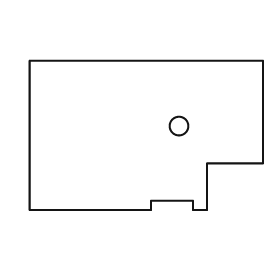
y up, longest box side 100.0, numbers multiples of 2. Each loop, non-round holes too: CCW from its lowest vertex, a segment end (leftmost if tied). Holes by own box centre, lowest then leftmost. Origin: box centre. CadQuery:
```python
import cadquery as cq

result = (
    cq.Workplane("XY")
    .moveTo(-50.0, -32.0)
    .lineTo(2.0, -32.0)
    .lineTo(2.0, -28.0)
    .lineTo(20.0, -28.0)
    .lineTo(20.0, -32.0)
    .lineTo(26.0, -32.0)
    .lineTo(26.0, -12.0)
    .lineTo(50.0, -12.0)
    .lineTo(50.0, 32.0)
    .lineTo(-50.0, 32.0)
    .close()
    .moveTo(14.0, 4.0)
    .circle(4.0)
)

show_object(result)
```